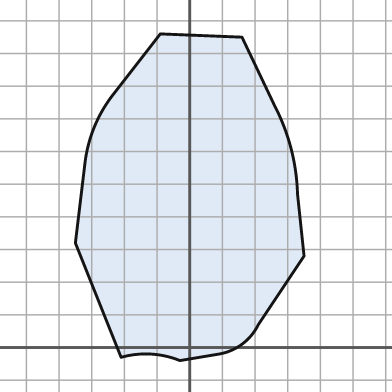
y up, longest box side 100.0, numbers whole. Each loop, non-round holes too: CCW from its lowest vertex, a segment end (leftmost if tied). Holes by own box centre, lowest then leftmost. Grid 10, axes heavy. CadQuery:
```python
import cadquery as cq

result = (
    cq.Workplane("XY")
    .moveTo(-3.0, -4.0)
    .lineTo(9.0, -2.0)
    .threePointArc((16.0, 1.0), (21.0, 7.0))
    .lineTo(35.0, 28.0)
    .lineTo(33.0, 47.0)
    .threePointArc((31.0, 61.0), (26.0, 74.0))
    .lineTo(16.0, 95.0)
    .lineTo(-9.0, 96.0)
    .lineTo(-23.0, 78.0)
    .threePointArc((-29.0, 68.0), (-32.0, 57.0))
    .lineTo(-35.0, 32.0)
    .lineTo(-21.0, -3.0)
    .threePointArc((-12.0, -2.0), (-3.0, -4.0))
    .close()
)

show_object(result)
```